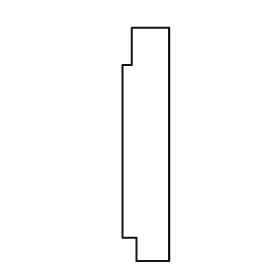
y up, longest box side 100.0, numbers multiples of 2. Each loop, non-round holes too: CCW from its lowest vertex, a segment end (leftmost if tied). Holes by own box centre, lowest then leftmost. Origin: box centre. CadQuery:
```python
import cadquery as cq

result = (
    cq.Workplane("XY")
    .moveTo(-4.0, -50.0)
    .lineTo(10.0, -50.0)
    .lineTo(10.0, 50.0)
    .lineTo(-6.0, 50.0)
    .lineTo(-6.0, 34.0)
    .lineTo(-10.0, 34.0)
    .lineTo(-10.0, -40.0)
    .lineTo(-4.0, -40.0)
    .close()
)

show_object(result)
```